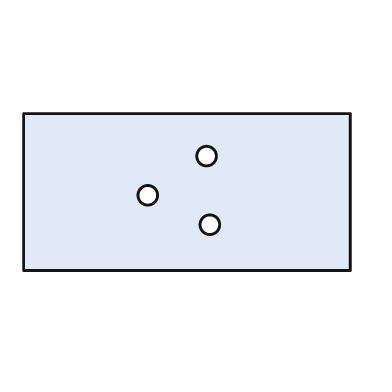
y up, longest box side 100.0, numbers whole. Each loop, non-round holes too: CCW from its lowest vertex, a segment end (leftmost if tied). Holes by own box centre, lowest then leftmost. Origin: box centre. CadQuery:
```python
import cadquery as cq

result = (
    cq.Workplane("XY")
    .moveTo(-50.0, -24.0)
    .lineTo(50.0, -24.0)
    .lineTo(50.0, 24.0)
    .lineTo(-50.0, 24.0)
    .close()
    .moveTo(7.0, -10.0)
    .circle(3.0)
    .moveTo(-12.0, -1.0)
    .circle(3.0)
    .moveTo(6.0, 11.0)
    .circle(3.0)
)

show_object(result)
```